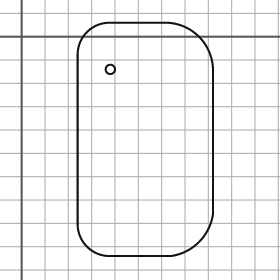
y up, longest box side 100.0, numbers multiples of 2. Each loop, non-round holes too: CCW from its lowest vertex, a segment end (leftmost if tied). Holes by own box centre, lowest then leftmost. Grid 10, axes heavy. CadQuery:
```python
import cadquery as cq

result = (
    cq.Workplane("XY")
    .moveTo(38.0, -94.0)
    .lineTo(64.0, -94.0)
    .threePointArc((76.0, -88.0), (82.0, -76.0))
    .lineTo(82.0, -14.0)
    .threePointArc((76.0, 0.0), (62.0, 6.0))
    .lineTo(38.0, 6.0)
    .threePointArc((28.0, 2.0), (24.0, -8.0))
    .lineTo(24.0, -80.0)
    .threePointArc((28.0, -90.0), (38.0, -94.0))
    .close()
    .moveTo(38.0, -14.0)
    .circle(2.0)
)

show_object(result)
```